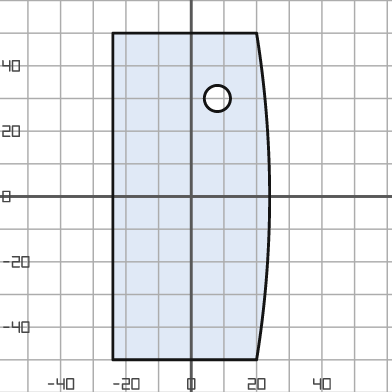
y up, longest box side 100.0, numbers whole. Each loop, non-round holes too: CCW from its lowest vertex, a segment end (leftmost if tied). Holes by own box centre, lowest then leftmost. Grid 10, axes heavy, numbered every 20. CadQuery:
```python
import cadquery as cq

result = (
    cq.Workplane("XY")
    .moveTo(-24.0, -50.0)
    .lineTo(20.0, -50.0)
    .threePointArc((24.0, 0.0), (20.0, 50.0))
    .lineTo(-24.0, 50.0)
    .close()
    .moveTo(8.0, 30.0)
    .circle(4.0)
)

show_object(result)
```